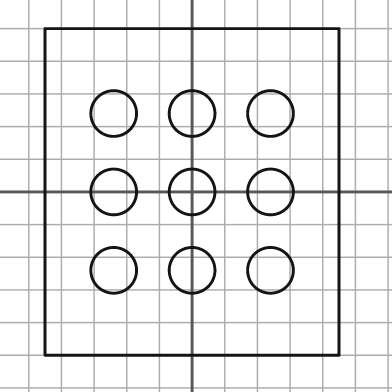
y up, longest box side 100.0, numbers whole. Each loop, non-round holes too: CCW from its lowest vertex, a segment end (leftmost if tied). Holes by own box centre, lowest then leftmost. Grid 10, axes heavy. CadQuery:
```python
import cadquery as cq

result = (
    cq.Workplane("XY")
    .moveTo(-45.0, -50.0)
    .lineTo(45.0, -50.0)
    .lineTo(45.0, 50.0)
    .lineTo(-45.0, 50.0)
    .close()
    .moveTo(-24.0, -24.0)
    .circle(7.0)
    .moveTo(0.0, -24.0)
    .circle(7.0)
    .moveTo(24.0, -24.0)
    .circle(7.0)
    .moveTo(-24.0, 0.0)
    .circle(7.0)
    .moveTo(0.0, 0.0)
    .circle(7.0)
    .moveTo(24.0, 0.0)
    .circle(7.0)
    .moveTo(-24.0, 24.0)
    .circle(7.0)
    .moveTo(0.0, 24.0)
    .circle(7.0)
    .moveTo(24.0, 24.0)
    .circle(7.0)
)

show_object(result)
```